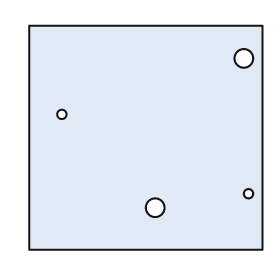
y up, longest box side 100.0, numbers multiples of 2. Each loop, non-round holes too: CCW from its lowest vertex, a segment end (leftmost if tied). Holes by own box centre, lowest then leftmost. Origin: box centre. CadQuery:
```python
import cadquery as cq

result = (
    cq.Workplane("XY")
    .moveTo(-50.0, -48.0)
    .lineTo(50.0, -48.0)
    .lineTo(50.0, 48.0)
    .lineTo(-50.0, 48.0)
    .close()
    .moveTo(4.0, -30.0)
    .circle(4.0)
    .moveTo(44.0, -24.0)
    .circle(2.0)
    .moveTo(-36.0, 10.0)
    .circle(2.0)
    .moveTo(42.0, 34.0)
    .circle(4.0)
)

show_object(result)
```